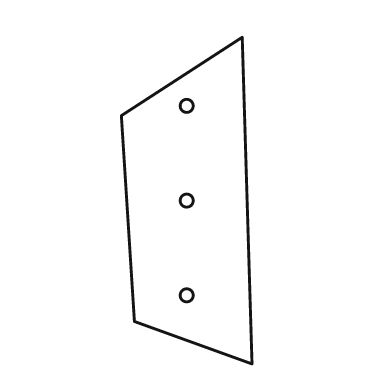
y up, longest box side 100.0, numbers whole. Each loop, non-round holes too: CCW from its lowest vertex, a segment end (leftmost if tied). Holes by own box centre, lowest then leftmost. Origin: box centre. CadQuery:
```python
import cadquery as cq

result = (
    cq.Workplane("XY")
    .moveTo(20.0, -50.0)
    .lineTo(17.0, 50.0)
    .lineTo(-20.0, 26.0)
    .lineTo(-16.0, -37.0)
    .close()
    .moveTo(0.0, -29.0)
    .circle(2.0)
    .moveTo(0.0, 0.0)
    .circle(2.0)
    .moveTo(0.0, 29.0)
    .circle(2.0)
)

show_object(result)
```